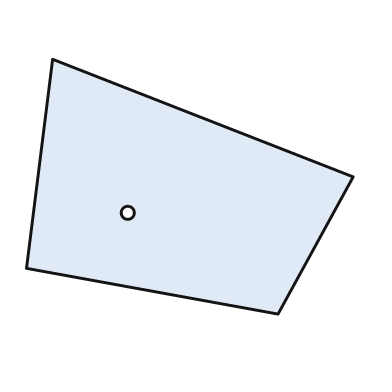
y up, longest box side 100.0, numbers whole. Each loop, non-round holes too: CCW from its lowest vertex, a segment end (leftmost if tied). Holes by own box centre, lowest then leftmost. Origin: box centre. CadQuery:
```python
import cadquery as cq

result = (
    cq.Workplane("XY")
    .moveTo(27.0, -39.0)
    .lineTo(50.0, 3.0)
    .lineTo(-42.0, 39.0)
    .lineTo(-50.0, -25.0)
    .close()
    .moveTo(-19.0, -8.0)
    .circle(2.0)
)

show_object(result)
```